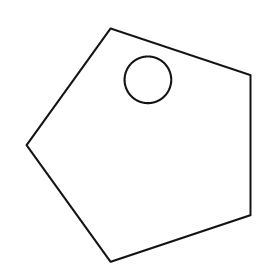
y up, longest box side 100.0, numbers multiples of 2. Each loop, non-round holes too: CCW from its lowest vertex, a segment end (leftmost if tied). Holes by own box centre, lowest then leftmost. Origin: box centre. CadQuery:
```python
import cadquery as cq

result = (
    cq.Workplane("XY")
    .moveTo(-12.0, -50.0)
    .lineTo(48.0, -30.0)
    .lineTo(48.0, 30.0)
    .lineTo(-12.0, 50.0)
    .lineTo(-48.0, 0.0)
    .close()
    .moveTo(4.0, 28.0)
    .circle(10.0)
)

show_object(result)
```